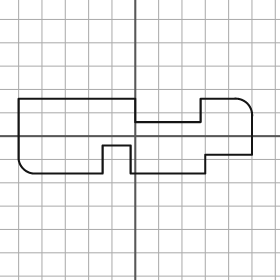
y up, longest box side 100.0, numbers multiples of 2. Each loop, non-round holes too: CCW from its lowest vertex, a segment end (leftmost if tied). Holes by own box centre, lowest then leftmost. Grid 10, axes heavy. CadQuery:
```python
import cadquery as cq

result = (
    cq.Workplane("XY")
    .moveTo(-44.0, -16.0)
    .lineTo(-14.0, -16.0)
    .lineTo(-14.0, -4.0)
    .lineTo(-2.0, -4.0)
    .lineTo(-2.0, -16.0)
    .lineTo(30.0, -16.0)
    .lineTo(30.0, -8.0)
    .lineTo(50.0, -8.0)
    .lineTo(50.0, 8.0)
    .threePointArc((48.0, 14.0), (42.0, 16.0))
    .lineTo(28.0, 16.0)
    .lineTo(28.0, 6.0)
    .lineTo(0.0, 6.0)
    .lineTo(0.0, 16.0)
    .lineTo(-50.0, 16.0)
    .lineTo(-50.0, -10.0)
    .threePointArc((-48.0, -14.0), (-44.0, -16.0))
    .close()
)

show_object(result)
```